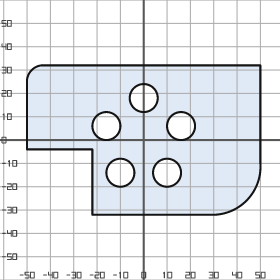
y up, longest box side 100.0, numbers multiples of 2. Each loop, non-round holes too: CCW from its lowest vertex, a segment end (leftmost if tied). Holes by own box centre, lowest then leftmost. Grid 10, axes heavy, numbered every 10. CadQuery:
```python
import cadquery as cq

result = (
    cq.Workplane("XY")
    .moveTo(-22.0, -32.0)
    .lineTo(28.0, -32.0)
    .threePointArc((44.0, -26.0), (50.0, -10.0))
    .lineTo(50.0, 32.0)
    .lineTo(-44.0, 32.0)
    .threePointArc((-48.0, 30.0), (-50.0, 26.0))
    .lineTo(-50.0, -4.0)
    .lineTo(-22.0, -4.0)
    .close()
    .moveTo(-10.0, -14.0)
    .circle(6.0)
    .moveTo(10.0, -14.0)
    .circle(6.0)
    .moveTo(-16.0, 6.0)
    .circle(6.0)
    .moveTo(16.0, 6.0)
    .circle(6.0)
    .moveTo(0.0, 18.0)
    .circle(6.0)
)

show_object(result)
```